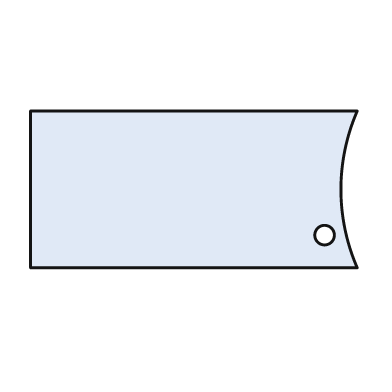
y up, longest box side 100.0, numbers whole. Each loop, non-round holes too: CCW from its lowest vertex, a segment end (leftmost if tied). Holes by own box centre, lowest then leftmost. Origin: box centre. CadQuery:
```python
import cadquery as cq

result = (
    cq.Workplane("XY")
    .moveTo(-50.0, -24.0)
    .lineTo(50.0, -24.0)
    .threePointArc((45.0, 0.0), (50.0, 24.0))
    .lineTo(-50.0, 24.0)
    .close()
    .moveTo(40.0, -14.0)
    .circle(3.0)
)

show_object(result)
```